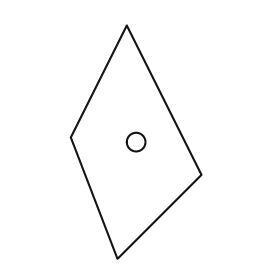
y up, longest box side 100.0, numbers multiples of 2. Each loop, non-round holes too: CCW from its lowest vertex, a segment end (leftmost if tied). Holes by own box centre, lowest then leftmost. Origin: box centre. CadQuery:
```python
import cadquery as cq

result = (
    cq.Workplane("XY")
    .moveTo(-8.0, -50.0)
    .lineTo(28.0, -14.0)
    .lineTo(-4.0, 50.0)
    .lineTo(-28.0, 2.0)
    .close()
    .moveTo(0.0, 0.0)
    .circle(4.0)
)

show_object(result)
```